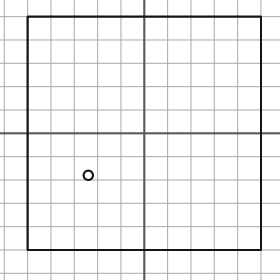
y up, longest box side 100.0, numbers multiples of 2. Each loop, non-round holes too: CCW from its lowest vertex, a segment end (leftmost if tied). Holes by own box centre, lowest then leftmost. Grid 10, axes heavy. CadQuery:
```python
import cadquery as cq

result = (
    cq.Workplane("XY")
    .moveTo(-50.0, -50.0)
    .lineTo(50.0, -50.0)
    .lineTo(50.0, 50.0)
    .lineTo(-50.0, 50.0)
    .close()
    .moveTo(-24.0, -18.0)
    .circle(2.0)
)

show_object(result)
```